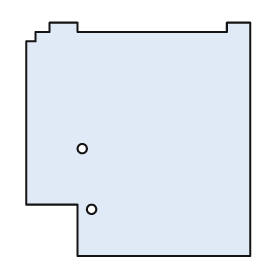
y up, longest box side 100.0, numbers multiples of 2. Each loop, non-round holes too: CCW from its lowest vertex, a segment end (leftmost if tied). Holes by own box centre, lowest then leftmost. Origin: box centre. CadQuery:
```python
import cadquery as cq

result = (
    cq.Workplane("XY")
    .moveTo(-26.0, -50.0)
    .lineTo(48.0, -50.0)
    .lineTo(48.0, 50.0)
    .lineTo(38.0, 50.0)
    .lineTo(38.0, 46.0)
    .lineTo(-26.0, 46.0)
    .lineTo(-26.0, 50.0)
    .lineTo(-38.0, 50.0)
    .lineTo(-38.0, 46.0)
    .lineTo(-44.0, 46.0)
    .lineTo(-44.0, 42.0)
    .lineTo(-48.0, 42.0)
    .lineTo(-48.0, -28.0)
    .lineTo(-26.0, -28.0)
    .close()
    .moveTo(-20.0, -30.0)
    .circle(2.0)
    .moveTo(-24.0, -4.0)
    .circle(2.0)
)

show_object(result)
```